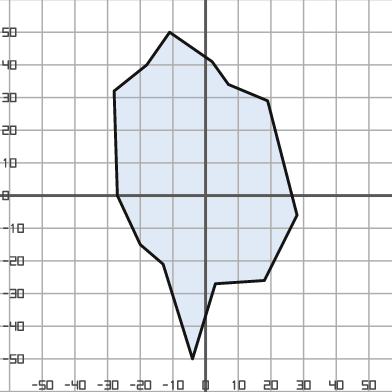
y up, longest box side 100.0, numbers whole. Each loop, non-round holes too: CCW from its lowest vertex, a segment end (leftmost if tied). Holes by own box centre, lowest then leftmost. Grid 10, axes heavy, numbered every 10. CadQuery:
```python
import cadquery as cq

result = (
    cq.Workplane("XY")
    .moveTo(-4.0, -50.0)
    .lineTo(3.0, -27.0)
    .lineTo(18.0, -26.0)
    .lineTo(28.0, -6.0)
    .lineTo(19.0, 29.0)
    .lineTo(7.0, 34.0)
    .lineTo(2.0, 41.0)
    .lineTo(-11.0, 50.0)
    .lineTo(-18.0, 40.0)
    .lineTo(-28.0, 32.0)
    .lineTo(-27.0, 0.0)
    .lineTo(-20.0, -15.0)
    .lineTo(-13.0, -21.0)
    .close()
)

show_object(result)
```